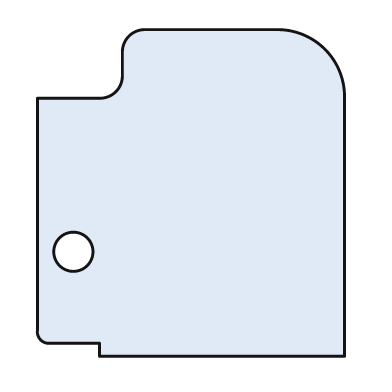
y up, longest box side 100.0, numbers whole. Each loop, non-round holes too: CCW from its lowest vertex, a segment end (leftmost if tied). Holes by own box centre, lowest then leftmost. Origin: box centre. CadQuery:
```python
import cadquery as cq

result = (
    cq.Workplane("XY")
    .moveTo(-28.0, -50.0)
    .lineTo(47.0, -50.0)
    .lineTo(47.0, 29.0)
    .threePointArc((41.0, 44.0), (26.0, 50.0))
    .lineTo(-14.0, 50.0)
    .threePointArc((-19.0, 48.0), (-21.0, 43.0))
    .lineTo(-21.0, 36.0)
    .threePointArc((-23.0, 31.0), (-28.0, 29.0))
    .lineTo(-47.0, 29.0)
    .lineTo(-47.0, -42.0)
    .threePointArc((-46.0, -45.0), (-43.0, -46.0))
    .lineTo(-28.0, -46.0)
    .close()
    .moveTo(-36.0, -18.0)
    .circle(6.0)
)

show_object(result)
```